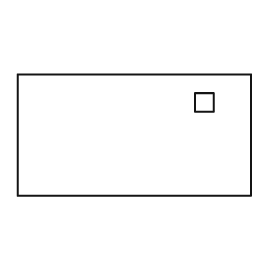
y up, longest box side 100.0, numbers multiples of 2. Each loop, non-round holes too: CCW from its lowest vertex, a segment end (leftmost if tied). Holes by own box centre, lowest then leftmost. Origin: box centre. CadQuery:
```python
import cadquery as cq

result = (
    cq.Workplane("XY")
    .moveTo(-50.0, -26.0)
    .lineTo(50.0, -26.0)
    .lineTo(50.0, 26.0)
    .lineTo(-50.0, 26.0)
    .close()
    .moveTo(26.0, 10.0)
    .lineTo(34.0, 10.0)
    .lineTo(34.0, 18.0)
    .lineTo(26.0, 18.0)
    .close()
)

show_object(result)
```